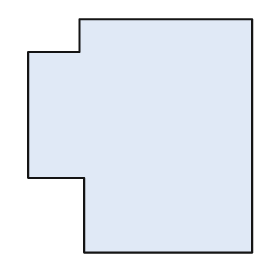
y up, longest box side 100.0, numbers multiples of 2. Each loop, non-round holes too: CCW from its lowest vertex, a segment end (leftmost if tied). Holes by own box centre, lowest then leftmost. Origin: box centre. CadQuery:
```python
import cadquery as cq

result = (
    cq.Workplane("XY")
    .moveTo(-24.0, -50.0)
    .lineTo(48.0, -50.0)
    .lineTo(48.0, 50.0)
    .lineTo(-26.0, 50.0)
    .lineTo(-26.0, 36.0)
    .lineTo(-48.0, 36.0)
    .lineTo(-48.0, -18.0)
    .lineTo(-24.0, -18.0)
    .close()
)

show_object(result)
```